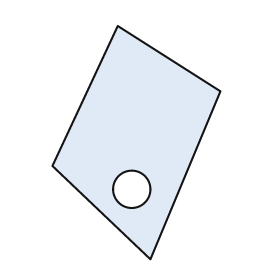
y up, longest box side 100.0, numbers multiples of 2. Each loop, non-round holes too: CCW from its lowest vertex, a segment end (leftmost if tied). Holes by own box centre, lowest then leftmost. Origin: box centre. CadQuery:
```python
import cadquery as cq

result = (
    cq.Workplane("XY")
    .moveTo(6.0, -50.0)
    .lineTo(36.0, 22.0)
    .lineTo(-8.0, 50.0)
    .lineTo(-36.0, -10.0)
    .close()
    .moveTo(-2.0, -20.0)
    .circle(8.0)
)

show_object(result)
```